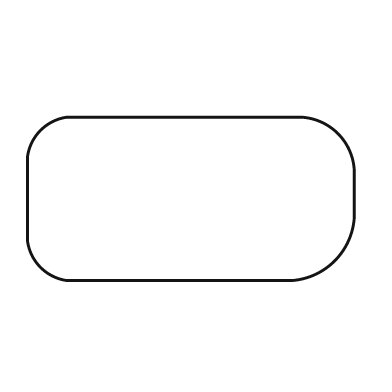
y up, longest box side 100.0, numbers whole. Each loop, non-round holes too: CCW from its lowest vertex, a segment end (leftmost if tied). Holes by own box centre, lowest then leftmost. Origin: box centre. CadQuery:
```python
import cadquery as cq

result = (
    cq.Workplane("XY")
    .moveTo(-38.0, -25.0)
    .lineTo(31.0, -25.0)
    .threePointArc((44.0, -19.0), (50.0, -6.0))
    .lineTo(50.0, 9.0)
    .threePointArc((45.0, 20.0), (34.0, 25.0))
    .lineTo(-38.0, 25.0)
    .threePointArc((-46.0, 21.0), (-50.0, 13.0))
    .lineTo(-50.0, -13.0)
    .threePointArc((-46.0, -21.0), (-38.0, -25.0))
    .close()
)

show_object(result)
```